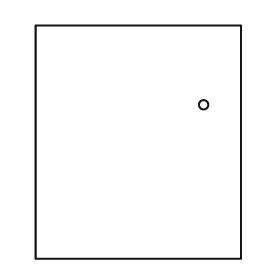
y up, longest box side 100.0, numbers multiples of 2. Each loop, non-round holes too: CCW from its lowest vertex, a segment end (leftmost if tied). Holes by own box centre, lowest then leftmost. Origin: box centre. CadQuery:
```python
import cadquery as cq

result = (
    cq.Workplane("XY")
    .moveTo(-44.0, -50.0)
    .lineTo(44.0, -50.0)
    .lineTo(44.0, 50.0)
    .lineTo(-44.0, 50.0)
    .close()
    .moveTo(28.0, 16.0)
    .circle(2.0)
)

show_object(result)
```